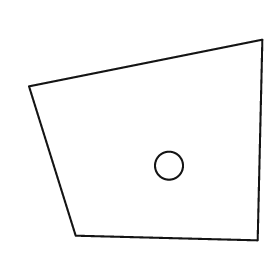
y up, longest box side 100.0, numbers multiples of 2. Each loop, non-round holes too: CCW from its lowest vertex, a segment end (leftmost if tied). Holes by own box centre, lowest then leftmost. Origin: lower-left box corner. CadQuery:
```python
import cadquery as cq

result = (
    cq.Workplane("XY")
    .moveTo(98.0, 0.0)
    .lineTo(100.0, 86.0)
    .lineTo(0.0, 66.0)
    .lineTo(20.0, 2.0)
    .close()
    .moveTo(60.0, 32.0)
    .circle(6.0)
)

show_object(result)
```